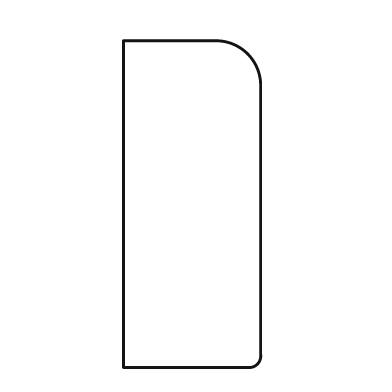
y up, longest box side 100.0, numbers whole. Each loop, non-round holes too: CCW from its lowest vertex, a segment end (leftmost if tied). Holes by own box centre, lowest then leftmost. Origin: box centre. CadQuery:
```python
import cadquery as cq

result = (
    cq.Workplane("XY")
    .moveTo(-21.0, -50.0)
    .lineTo(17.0, -50.0)
    .threePointArc((20.0, -49.0), (21.0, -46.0))
    .lineTo(21.0, 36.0)
    .threePointArc((17.0, 46.0), (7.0, 50.0))
    .lineTo(-21.0, 50.0)
    .close()
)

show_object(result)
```